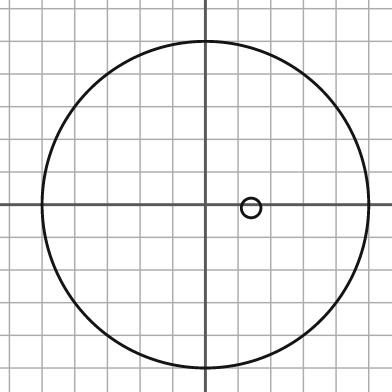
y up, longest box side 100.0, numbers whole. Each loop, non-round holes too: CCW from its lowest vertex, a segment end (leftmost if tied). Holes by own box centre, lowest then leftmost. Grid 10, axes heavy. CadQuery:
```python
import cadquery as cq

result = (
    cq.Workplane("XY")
    .moveTo(0.0, 0.0)
    .circle(50.0)
    .moveTo(14.0, -1.0)
    .circle(3.0)
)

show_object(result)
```